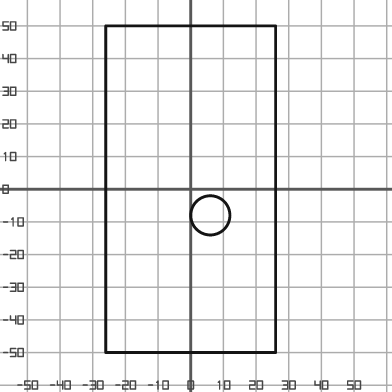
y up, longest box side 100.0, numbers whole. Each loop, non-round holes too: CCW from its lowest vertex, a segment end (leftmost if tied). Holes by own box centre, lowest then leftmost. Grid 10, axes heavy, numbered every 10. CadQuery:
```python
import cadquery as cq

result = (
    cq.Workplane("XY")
    .moveTo(-26.0, -50.0)
    .lineTo(26.0, -50.0)
    .lineTo(26.0, 50.0)
    .lineTo(-26.0, 50.0)
    .close()
    .moveTo(6.0, -8.0)
    .circle(6.0)
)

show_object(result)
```